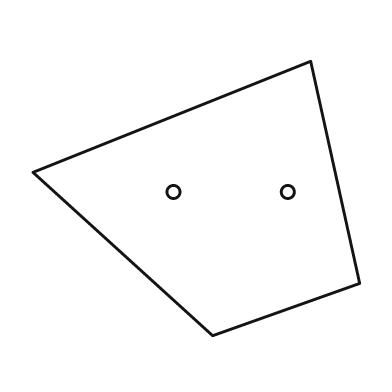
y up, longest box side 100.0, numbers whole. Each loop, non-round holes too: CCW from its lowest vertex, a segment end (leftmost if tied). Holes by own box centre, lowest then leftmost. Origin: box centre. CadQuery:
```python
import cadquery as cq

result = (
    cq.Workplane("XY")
    .moveTo(5.0, -42.0)
    .lineTo(50.0, -26.0)
    .lineTo(35.0, 42.0)
    .lineTo(-50.0, 8.0)
    .close()
    .moveTo(-7.0, 2.0)
    .circle(2.0)
    .moveTo(28.0, 2.0)
    .circle(2.0)
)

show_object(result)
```